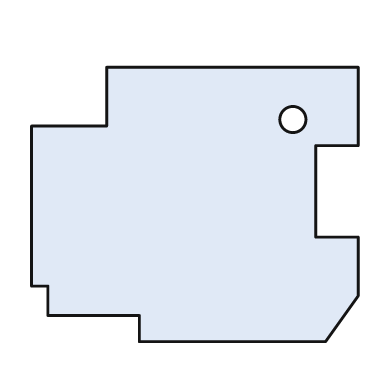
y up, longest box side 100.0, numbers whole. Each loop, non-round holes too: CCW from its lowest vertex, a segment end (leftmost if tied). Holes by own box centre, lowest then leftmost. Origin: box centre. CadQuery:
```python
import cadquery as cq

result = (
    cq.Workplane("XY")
    .moveTo(-17.0, -42.0)
    .lineTo(40.0, -42.0)
    .lineTo(50.0, -28.0)
    .lineTo(50.0, -10.0)
    .lineTo(37.0, -10.0)
    .lineTo(37.0, 18.0)
    .lineTo(50.0, 18.0)
    .lineTo(50.0, 42.0)
    .lineTo(-27.0, 42.0)
    .lineTo(-27.0, 24.0)
    .lineTo(-50.0, 24.0)
    .lineTo(-50.0, -25.0)
    .lineTo(-45.0, -25.0)
    .lineTo(-45.0, -34.0)
    .lineTo(-17.0, -34.0)
    .close()
    .moveTo(30.0, 26.0)
    .circle(4.0)
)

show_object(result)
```